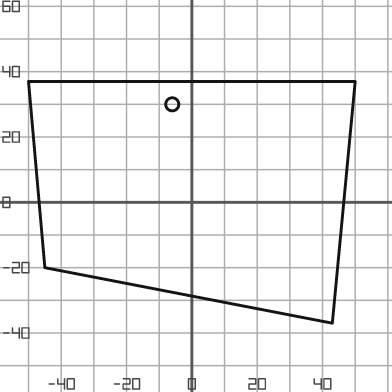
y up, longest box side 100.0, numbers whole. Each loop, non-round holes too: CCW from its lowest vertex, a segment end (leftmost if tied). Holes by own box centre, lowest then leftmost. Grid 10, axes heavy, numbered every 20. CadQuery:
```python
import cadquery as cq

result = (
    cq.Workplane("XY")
    .moveTo(43.0, -37.0)
    .lineTo(50.0, 37.0)
    .lineTo(-50.0, 37.0)
    .lineTo(-45.0, -20.0)
    .close()
    .moveTo(-6.0, 30.0)
    .circle(2.0)
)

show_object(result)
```